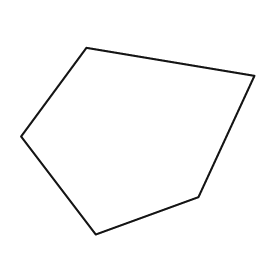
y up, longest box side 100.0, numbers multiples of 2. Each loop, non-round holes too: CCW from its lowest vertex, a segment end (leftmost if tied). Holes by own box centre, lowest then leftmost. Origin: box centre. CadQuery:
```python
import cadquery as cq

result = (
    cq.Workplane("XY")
    .moveTo(-18.0, -40.0)
    .lineTo(26.0, -24.0)
    .lineTo(50.0, 28.0)
    .lineTo(-22.0, 40.0)
    .lineTo(-50.0, 2.0)
    .close()
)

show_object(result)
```